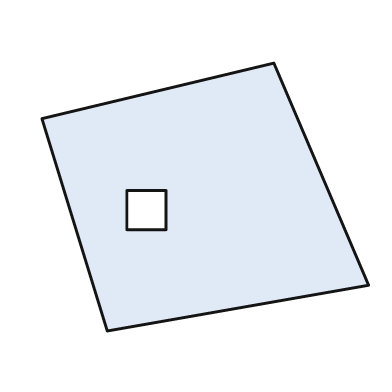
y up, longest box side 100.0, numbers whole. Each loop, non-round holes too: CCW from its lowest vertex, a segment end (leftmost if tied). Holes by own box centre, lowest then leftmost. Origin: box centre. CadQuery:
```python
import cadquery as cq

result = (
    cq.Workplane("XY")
    .moveTo(-30.0, -41.0)
    .lineTo(50.0, -27.0)
    .lineTo(21.0, 41.0)
    .lineTo(-50.0, 24.0)
    .close()
    .moveTo(-24.0, -10.0)
    .lineTo(-12.0, -10.0)
    .lineTo(-12.0, 2.0)
    .lineTo(-24.0, 2.0)
    .close()
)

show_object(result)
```